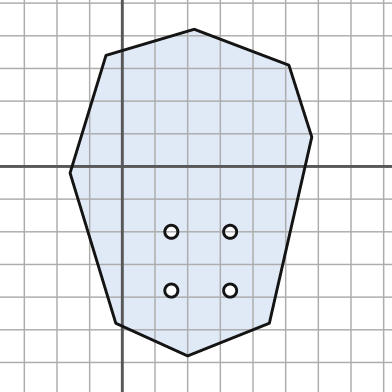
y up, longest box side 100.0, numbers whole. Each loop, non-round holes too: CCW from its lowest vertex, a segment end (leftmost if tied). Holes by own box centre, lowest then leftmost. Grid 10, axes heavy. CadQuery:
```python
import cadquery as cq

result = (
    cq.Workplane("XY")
    .moveTo(20.0, -58.0)
    .lineTo(45.0, -48.0)
    .lineTo(58.0, 9.0)
    .lineTo(51.0, 31.0)
    .lineTo(22.0, 42.0)
    .lineTo(-5.0, 34.0)
    .lineTo(-16.0, -2.0)
    .lineTo(-2.0, -48.0)
    .close()
    .moveTo(15.0, -38.0)
    .circle(2.0)
    .moveTo(33.0, -38.0)
    .circle(2.0)
    .moveTo(15.0, -20.0)
    .circle(2.0)
    .moveTo(33.0, -20.0)
    .circle(2.0)
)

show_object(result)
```